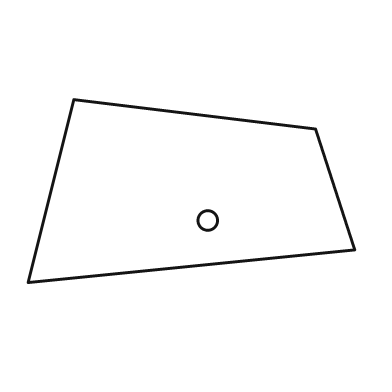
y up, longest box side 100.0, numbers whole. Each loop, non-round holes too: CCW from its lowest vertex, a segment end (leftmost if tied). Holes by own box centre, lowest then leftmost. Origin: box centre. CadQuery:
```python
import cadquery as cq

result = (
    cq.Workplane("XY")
    .moveTo(-50.0, -28.0)
    .lineTo(50.0, -18.0)
    .lineTo(38.0, 19.0)
    .lineTo(-36.0, 28.0)
    .close()
    .moveTo(5.0, -9.0)
    .circle(3.0)
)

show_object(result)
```